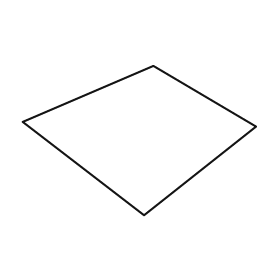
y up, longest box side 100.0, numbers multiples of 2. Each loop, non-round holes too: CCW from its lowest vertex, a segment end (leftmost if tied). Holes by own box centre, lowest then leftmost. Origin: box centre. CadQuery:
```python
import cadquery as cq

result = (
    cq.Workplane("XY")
    .moveTo(2.0, -32.0)
    .lineTo(50.0, 6.0)
    .lineTo(6.0, 32.0)
    .lineTo(-50.0, 8.0)
    .close()
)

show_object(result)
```